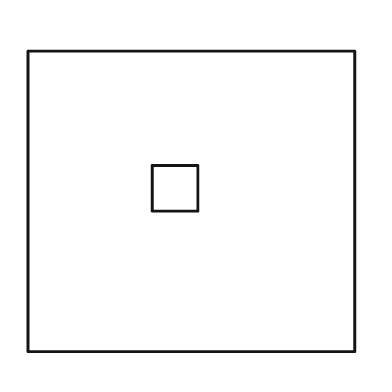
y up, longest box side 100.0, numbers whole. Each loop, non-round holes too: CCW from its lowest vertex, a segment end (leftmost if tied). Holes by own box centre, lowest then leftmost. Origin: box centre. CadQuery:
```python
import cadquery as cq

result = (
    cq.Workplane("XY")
    .moveTo(-50.0, -46.0)
    .lineTo(50.0, -46.0)
    .lineTo(50.0, 46.0)
    .lineTo(-50.0, 46.0)
    .close()
    .moveTo(-12.0, -3.0)
    .lineTo(2.0, -3.0)
    .lineTo(2.0, 11.0)
    .lineTo(-12.0, 11.0)
    .close()
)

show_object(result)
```